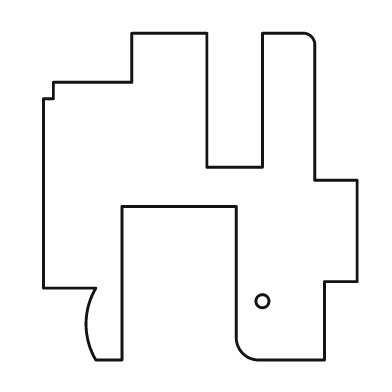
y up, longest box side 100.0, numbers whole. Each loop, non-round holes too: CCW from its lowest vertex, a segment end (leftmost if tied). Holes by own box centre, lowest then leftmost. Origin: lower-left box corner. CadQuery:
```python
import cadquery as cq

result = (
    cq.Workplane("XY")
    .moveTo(16.0, 0.0)
    .lineTo(24.0, 0.0)
    .lineTo(24.0, 47.0)
    .lineTo(59.0, 47.0)
    .lineTo(59.0, 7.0)
    .threePointArc((61.0, 2.0), (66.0, 0.0))
    .lineTo(86.0, 0.0)
    .lineTo(86.0, 24.0)
    .lineTo(96.0, 24.0)
    .lineTo(96.0, 55.0)
    .lineTo(83.0, 55.0)
    .lineTo(83.0, 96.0)
    .threePointArc((82.0, 99.0), (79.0, 100.0))
    .lineTo(67.0, 100.0)
    .lineTo(67.0, 59.0)
    .lineTo(50.0, 59.0)
    .lineTo(50.0, 100.0)
    .lineTo(27.0, 100.0)
    .lineTo(27.0, 85.0)
    .lineTo(3.0, 85.0)
    .lineTo(3.0, 80.0)
    .lineTo(0.0, 80.0)
    .lineTo(0.0, 22.0)
    .lineTo(16.0, 22.0)
    .threePointArc((13.0, 11.0), (16.0, 0.0))
    .close()
    .moveTo(67.0, 18.0)
    .circle(2.0)
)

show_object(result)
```